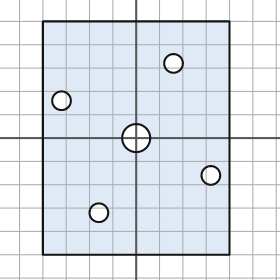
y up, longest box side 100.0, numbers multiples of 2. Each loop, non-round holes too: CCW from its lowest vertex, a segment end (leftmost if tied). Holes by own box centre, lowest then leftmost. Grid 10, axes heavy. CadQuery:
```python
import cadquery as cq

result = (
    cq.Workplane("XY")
    .moveTo(-40.0, -50.0)
    .lineTo(40.0, -50.0)
    .lineTo(40.0, 50.0)
    .lineTo(-40.0, 50.0)
    .close()
    .moveTo(-16.0, -32.0)
    .circle(4.0)
    .moveTo(32.0, -16.0)
    .circle(4.0)
    .moveTo(0.0, 0.0)
    .circle(6.0)
    .moveTo(-32.0, 16.0)
    .circle(4.0)
    .moveTo(16.0, 32.0)
    .circle(4.0)
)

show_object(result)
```